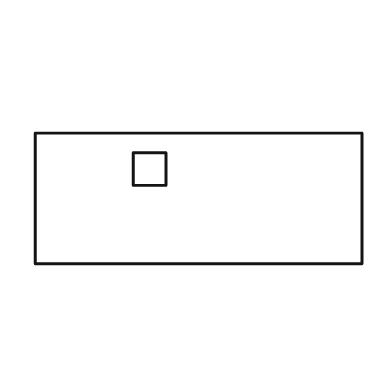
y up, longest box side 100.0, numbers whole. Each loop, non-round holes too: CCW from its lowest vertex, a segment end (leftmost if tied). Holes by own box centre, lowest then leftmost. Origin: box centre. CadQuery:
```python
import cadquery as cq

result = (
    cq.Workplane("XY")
    .moveTo(-50.0, -20.0)
    .lineTo(50.0, -20.0)
    .lineTo(50.0, 20.0)
    .lineTo(-50.0, 20.0)
    .close()
    .moveTo(-20.0, 4.0)
    .lineTo(-10.0, 4.0)
    .lineTo(-10.0, 14.0)
    .lineTo(-20.0, 14.0)
    .close()
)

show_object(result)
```